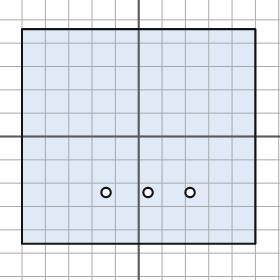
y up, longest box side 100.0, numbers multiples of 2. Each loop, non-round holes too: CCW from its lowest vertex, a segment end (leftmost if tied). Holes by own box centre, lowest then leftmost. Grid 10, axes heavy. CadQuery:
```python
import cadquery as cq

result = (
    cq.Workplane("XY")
    .moveTo(-50.0, -46.0)
    .lineTo(50.0, -46.0)
    .lineTo(50.0, 46.0)
    .lineTo(-50.0, 46.0)
    .close()
    .moveTo(-14.0, -24.0)
    .circle(2.0)
    .moveTo(4.0, -24.0)
    .circle(2.0)
    .moveTo(22.0, -24.0)
    .circle(2.0)
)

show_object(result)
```